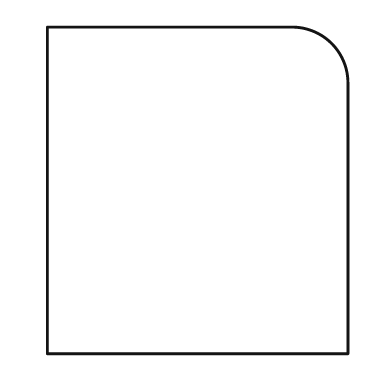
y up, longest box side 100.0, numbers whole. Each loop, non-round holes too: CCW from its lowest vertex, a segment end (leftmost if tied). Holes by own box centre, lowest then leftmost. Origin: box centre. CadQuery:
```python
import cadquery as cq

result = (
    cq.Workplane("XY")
    .moveTo(-46.0, -50.0)
    .lineTo(46.0, -50.0)
    .lineTo(46.0, 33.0)
    .threePointArc((41.0, 45.0), (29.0, 50.0))
    .lineTo(-46.0, 50.0)
    .close()
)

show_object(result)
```